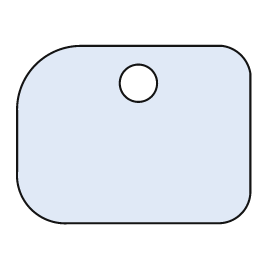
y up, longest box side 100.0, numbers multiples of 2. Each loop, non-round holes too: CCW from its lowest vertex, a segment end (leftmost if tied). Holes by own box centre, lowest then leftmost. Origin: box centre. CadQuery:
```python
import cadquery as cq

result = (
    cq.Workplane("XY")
    .moveTo(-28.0, -38.0)
    .lineTo(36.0, -38.0)
    .threePointArc((46.0, -34.0), (50.0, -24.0))
    .lineTo(50.0, 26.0)
    .threePointArc((46.0, 34.0), (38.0, 38.0))
    .lineTo(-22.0, 38.0)
    .threePointArc((-42.0, 30.0), (-50.0, 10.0))
    .lineTo(-50.0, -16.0)
    .threePointArc((-44.0, -32.0), (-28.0, -38.0))
    .close()
    .moveTo(2.0, 22.0)
    .circle(8.0)
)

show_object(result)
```